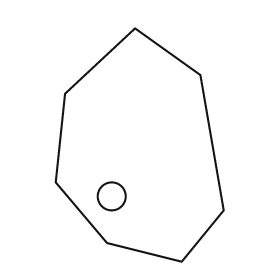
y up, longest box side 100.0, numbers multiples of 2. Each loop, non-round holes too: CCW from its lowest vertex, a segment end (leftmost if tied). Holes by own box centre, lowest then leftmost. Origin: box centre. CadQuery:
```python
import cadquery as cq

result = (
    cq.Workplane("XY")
    .moveTo(18.0, -50.0)
    .lineTo(36.0, -28.0)
    .lineTo(26.0, 30.0)
    .lineTo(-2.0, 50.0)
    .lineTo(-32.0, 22.0)
    .lineTo(-36.0, -16.0)
    .lineTo(-14.0, -42.0)
    .close()
    .moveTo(-12.0, -22.0)
    .circle(6.0)
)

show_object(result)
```